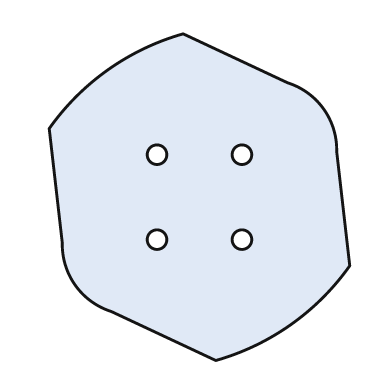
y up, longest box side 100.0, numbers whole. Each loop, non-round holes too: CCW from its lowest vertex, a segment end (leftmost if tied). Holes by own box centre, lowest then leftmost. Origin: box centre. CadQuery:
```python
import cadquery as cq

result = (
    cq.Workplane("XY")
    .moveTo(5.0, -50.0)
    .threePointArc((28.0, -39.0), (46.0, -21.0))
    .lineTo(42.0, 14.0)
    .threePointArc((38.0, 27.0), (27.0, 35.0))
    .lineTo(-5.0, 50.0)
    .threePointArc((-28.0, 39.0), (-46.0, 21.0))
    .lineTo(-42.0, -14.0)
    .threePointArc((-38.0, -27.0), (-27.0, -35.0))
    .close()
    .moveTo(-13.0, -13.0)
    .circle(3.0)
    .moveTo(13.0, -13.0)
    .circle(3.0)
    .moveTo(-13.0, 13.0)
    .circle(3.0)
    .moveTo(13.0, 13.0)
    .circle(3.0)
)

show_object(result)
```